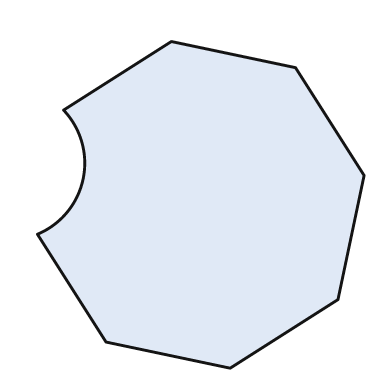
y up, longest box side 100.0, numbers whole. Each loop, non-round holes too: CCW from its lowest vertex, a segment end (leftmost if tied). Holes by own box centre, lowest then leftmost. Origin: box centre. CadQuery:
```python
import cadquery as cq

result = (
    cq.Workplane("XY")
    .moveTo(9.0, -50.0)
    .lineTo(42.0, -29.0)
    .lineTo(50.0, 9.0)
    .lineTo(29.0, 42.0)
    .lineTo(-9.0, 50.0)
    .lineTo(-42.0, 29.0)
    .threePointArc((-36.0, 8.0), (-50.0, -9.0))
    .lineTo(-29.0, -42.0)
    .close()
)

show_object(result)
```